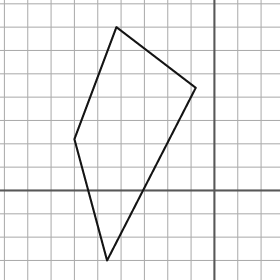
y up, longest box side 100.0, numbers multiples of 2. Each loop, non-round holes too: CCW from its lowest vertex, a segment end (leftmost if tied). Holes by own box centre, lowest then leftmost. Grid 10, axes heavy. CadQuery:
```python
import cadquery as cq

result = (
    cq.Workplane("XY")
    .moveTo(-46.0, -30.0)
    .lineTo(-8.0, 44.0)
    .lineTo(-42.0, 70.0)
    .lineTo(-60.0, 22.0)
    .close()
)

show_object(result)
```